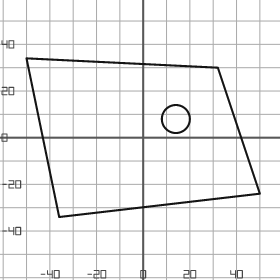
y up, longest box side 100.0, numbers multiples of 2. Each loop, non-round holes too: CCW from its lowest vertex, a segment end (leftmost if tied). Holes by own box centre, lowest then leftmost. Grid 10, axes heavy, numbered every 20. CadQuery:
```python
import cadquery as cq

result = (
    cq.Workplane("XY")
    .moveTo(-36.0, -34.0)
    .lineTo(50.0, -24.0)
    .lineTo(32.0, 30.0)
    .lineTo(-50.0, 34.0)
    .close()
    .moveTo(14.0, 8.0)
    .circle(6.0)
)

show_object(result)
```